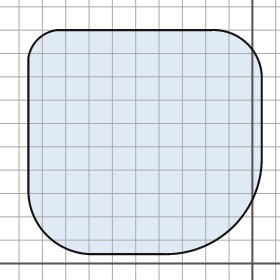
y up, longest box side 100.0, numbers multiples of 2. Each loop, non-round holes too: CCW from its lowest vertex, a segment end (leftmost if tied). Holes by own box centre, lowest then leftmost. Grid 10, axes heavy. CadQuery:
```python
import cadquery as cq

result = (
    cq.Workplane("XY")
    .moveTo(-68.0, 4.0)
    .lineTo(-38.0, 4.0)
    .threePointArc((-8.0, 16.0), (4.0, 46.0))
    .lineTo(4.0, 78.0)
    .threePointArc((-2.0, 94.0), (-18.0, 100.0))
    .lineTo(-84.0, 100.0)
    .threePointArc((-92.0, 96.0), (-96.0, 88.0))
    .lineTo(-96.0, 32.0)
    .threePointArc((-88.0, 12.0), (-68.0, 4.0))
    .close()
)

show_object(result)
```